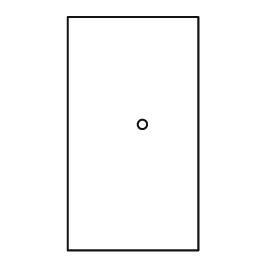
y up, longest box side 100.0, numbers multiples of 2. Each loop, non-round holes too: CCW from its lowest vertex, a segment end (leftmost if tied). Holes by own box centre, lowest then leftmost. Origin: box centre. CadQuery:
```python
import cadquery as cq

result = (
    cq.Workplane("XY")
    .moveTo(-28.0, -50.0)
    .lineTo(28.0, -50.0)
    .lineTo(28.0, 50.0)
    .lineTo(-28.0, 50.0)
    .close()
    .moveTo(4.0, 4.0)
    .circle(2.0)
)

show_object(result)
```